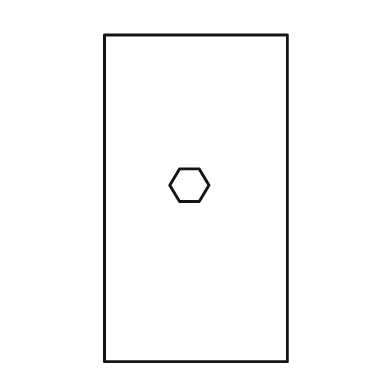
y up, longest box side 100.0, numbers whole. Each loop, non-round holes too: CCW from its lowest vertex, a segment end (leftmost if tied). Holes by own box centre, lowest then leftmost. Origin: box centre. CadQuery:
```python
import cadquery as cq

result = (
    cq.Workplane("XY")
    .moveTo(-28.0, -50.0)
    .lineTo(28.0, -50.0)
    .lineTo(28.0, 50.0)
    .lineTo(-28.0, 50.0)
    .close()
    .moveTo(-5.0, -1.0)
    .lineTo(1.0, -1.0)
    .lineTo(4.0, 4.0)
    .lineTo(1.0, 9.0)
    .lineTo(-5.0, 9.0)
    .lineTo(-8.0, 4.0)
    .close()
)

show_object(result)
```